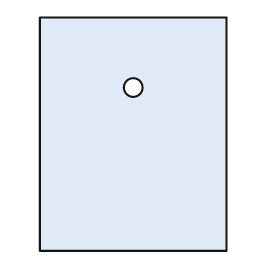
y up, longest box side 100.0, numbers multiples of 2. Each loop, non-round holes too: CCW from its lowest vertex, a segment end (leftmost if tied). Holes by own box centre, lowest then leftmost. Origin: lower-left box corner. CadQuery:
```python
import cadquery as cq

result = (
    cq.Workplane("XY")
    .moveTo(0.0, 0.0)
    .lineTo(80.0, 0.0)
    .lineTo(80.0, 100.0)
    .lineTo(0.0, 100.0)
    .close()
    .moveTo(40.0, 70.0)
    .circle(4.0)
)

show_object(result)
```